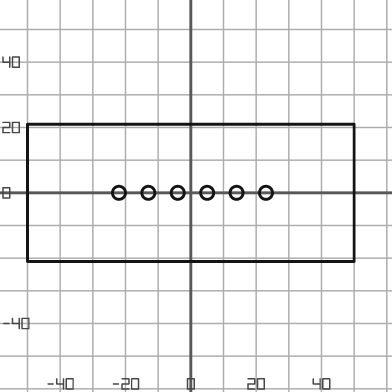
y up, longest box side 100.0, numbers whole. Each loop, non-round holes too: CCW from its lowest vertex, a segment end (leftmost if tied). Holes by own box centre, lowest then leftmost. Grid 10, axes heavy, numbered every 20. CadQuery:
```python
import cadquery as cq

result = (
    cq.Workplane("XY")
    .moveTo(-50.0, -21.0)
    .lineTo(50.0, -21.0)
    .lineTo(50.0, 21.0)
    .lineTo(-50.0, 21.0)
    .close()
    .moveTo(-22.0, 0.0)
    .circle(2.0)
    .moveTo(-13.0, 0.0)
    .circle(2.0)
    .moveTo(-4.0, 0.0)
    .circle(2.0)
    .moveTo(5.0, 0.0)
    .circle(2.0)
    .moveTo(14.0, 0.0)
    .circle(2.0)
    .moveTo(23.0, 0.0)
    .circle(2.0)
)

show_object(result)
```